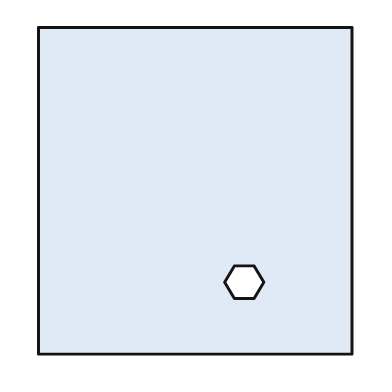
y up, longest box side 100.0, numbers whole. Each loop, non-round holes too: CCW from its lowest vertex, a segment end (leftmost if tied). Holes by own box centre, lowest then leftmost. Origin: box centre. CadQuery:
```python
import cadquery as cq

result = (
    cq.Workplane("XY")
    .moveTo(-48.0, -50.0)
    .lineTo(48.0, -50.0)
    .lineTo(48.0, 50.0)
    .lineTo(-48.0, 50.0)
    .close()
    .moveTo(12.0, -33.0)
    .lineTo(18.0, -33.0)
    .lineTo(21.0, -28.0)
    .lineTo(18.0, -23.0)
    .lineTo(12.0, -23.0)
    .lineTo(9.0, -28.0)
    .close()
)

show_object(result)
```